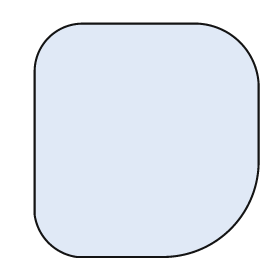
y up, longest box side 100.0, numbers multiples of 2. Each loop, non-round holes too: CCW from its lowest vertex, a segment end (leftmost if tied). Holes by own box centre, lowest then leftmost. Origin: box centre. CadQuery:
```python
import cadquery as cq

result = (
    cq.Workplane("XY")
    .moveTo(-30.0, -50.0)
    .lineTo(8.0, -50.0)
    .threePointArc((36.0, -38.0), (48.0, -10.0))
    .lineTo(48.0, 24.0)
    .threePointArc((40.0, 42.0), (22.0, 50.0))
    .lineTo(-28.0, 50.0)
    .threePointArc((-42.0, 44.0), (-48.0, 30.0))
    .lineTo(-48.0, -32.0)
    .threePointArc((-42.0, -44.0), (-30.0, -50.0))
    .close()
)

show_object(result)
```